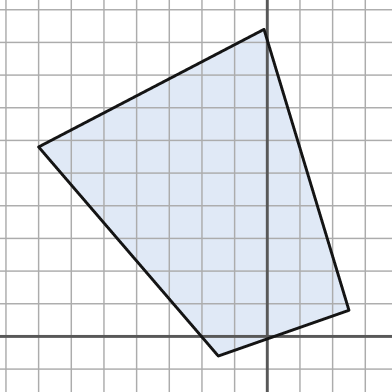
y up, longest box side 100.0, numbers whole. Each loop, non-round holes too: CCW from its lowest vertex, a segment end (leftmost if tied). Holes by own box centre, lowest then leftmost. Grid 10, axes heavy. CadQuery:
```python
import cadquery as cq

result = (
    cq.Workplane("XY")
    .moveTo(-15.0, -6.0)
    .lineTo(25.0, 8.0)
    .lineTo(-1.0, 94.0)
    .lineTo(-70.0, 58.0)
    .close()
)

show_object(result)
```